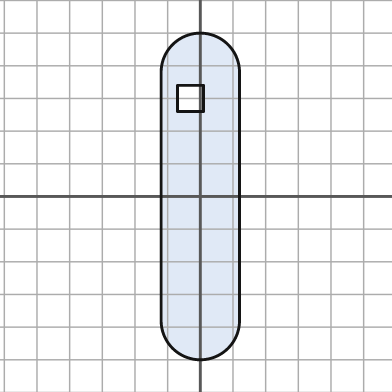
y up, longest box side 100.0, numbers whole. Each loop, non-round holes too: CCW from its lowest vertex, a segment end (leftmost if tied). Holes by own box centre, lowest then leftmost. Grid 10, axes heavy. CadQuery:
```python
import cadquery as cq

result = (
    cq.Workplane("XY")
    .moveTo(-12.0, -38.0)
    .threePointArc((0.0, -50.0), (12.0, -38.0))
    .lineTo(12.0, 38.0)
    .threePointArc((0.0, 50.0), (-12.0, 38.0))
    .close()
    .moveTo(-7.0, 26.0)
    .lineTo(1.0, 26.0)
    .lineTo(1.0, 34.0)
    .lineTo(-7.0, 34.0)
    .close()
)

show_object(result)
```